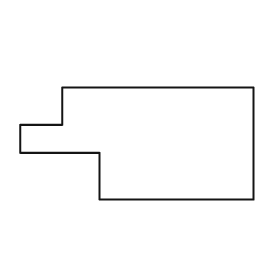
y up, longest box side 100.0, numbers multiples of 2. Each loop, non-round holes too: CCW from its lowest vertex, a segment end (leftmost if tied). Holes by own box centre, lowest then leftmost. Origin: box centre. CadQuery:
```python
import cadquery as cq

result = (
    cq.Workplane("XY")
    .moveTo(-16.0, -24.0)
    .lineTo(50.0, -24.0)
    .lineTo(50.0, 24.0)
    .lineTo(-32.0, 24.0)
    .lineTo(-32.0, 8.0)
    .lineTo(-50.0, 8.0)
    .lineTo(-50.0, -4.0)
    .lineTo(-16.0, -4.0)
    .close()
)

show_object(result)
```